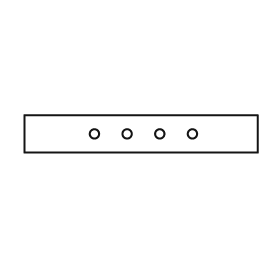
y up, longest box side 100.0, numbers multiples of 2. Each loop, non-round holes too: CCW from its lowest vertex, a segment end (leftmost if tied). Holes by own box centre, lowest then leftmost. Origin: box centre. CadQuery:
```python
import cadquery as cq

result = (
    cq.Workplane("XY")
    .moveTo(-50.0, -8.0)
    .lineTo(50.0, -8.0)
    .lineTo(50.0, 8.0)
    .lineTo(-50.0, 8.0)
    .close()
    .moveTo(-20.0, 0.0)
    .circle(2.0)
    .moveTo(-6.0, 0.0)
    .circle(2.0)
    .moveTo(8.0, 0.0)
    .circle(2.0)
    .moveTo(22.0, 0.0)
    .circle(2.0)
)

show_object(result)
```